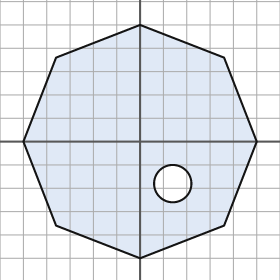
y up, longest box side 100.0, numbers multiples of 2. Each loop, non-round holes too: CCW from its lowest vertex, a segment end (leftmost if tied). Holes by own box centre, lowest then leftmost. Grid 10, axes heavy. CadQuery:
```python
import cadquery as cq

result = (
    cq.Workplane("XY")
    .moveTo(0.0, -50.0)
    .lineTo(36.0, -36.0)
    .lineTo(50.0, 0.0)
    .lineTo(36.0, 36.0)
    .lineTo(0.0, 50.0)
    .lineTo(-36.0, 36.0)
    .lineTo(-50.0, 0.0)
    .lineTo(-36.0, -36.0)
    .close()
    .moveTo(14.0, -18.0)
    .circle(8.0)
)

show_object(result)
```